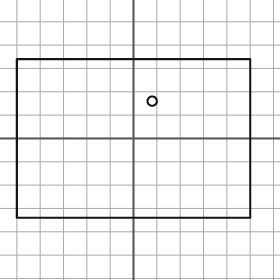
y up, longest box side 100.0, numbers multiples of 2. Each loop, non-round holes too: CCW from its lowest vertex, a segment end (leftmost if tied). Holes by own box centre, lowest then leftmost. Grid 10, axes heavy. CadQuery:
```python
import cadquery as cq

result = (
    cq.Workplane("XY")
    .moveTo(-50.0, -34.0)
    .lineTo(50.0, -34.0)
    .lineTo(50.0, 34.0)
    .lineTo(-50.0, 34.0)
    .close()
    .moveTo(8.0, 16.0)
    .circle(2.0)
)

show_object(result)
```